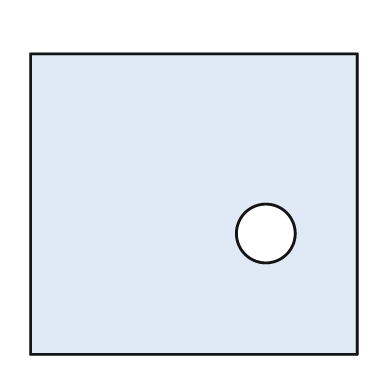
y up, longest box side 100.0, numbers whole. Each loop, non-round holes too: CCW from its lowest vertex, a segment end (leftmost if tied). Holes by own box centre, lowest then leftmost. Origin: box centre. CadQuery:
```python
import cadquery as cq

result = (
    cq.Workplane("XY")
    .moveTo(-50.0, -46.0)
    .lineTo(50.0, -46.0)
    .lineTo(50.0, 46.0)
    .lineTo(-50.0, 46.0)
    .close()
    .moveTo(22.0, -9.0)
    .circle(9.0)
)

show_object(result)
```